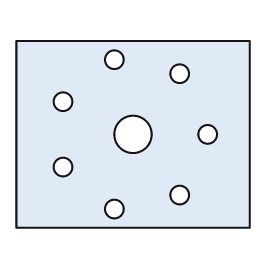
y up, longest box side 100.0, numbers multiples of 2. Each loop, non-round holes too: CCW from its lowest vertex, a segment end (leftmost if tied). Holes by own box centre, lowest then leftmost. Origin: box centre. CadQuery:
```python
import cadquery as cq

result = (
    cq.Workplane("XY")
    .moveTo(-50.0, -40.0)
    .lineTo(50.0, -40.0)
    .lineTo(50.0, 40.0)
    .lineTo(-50.0, 40.0)
    .close()
    .moveTo(-8.0, -32.0)
    .circle(4.0)
    .moveTo(20.0, -26.0)
    .circle(4.0)
    .moveTo(-30.0, -14.0)
    .circle(4.0)
    .moveTo(0.0, 0.0)
    .circle(8.0)
    .moveTo(32.0, 0.0)
    .circle(4.0)
    .moveTo(-30.0, 14.0)
    .circle(4.0)
    .moveTo(20.0, 26.0)
    .circle(4.0)
    .moveTo(-8.0, 32.0)
    .circle(4.0)
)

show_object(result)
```